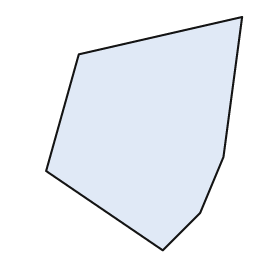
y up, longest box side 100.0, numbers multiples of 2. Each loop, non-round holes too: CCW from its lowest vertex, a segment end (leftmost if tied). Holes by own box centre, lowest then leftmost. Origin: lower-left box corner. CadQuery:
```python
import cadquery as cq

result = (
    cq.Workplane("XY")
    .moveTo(50.0, 0.0)
    .lineTo(66.0, 16.0)
    .lineTo(76.0, 40.0)
    .lineTo(84.0, 100.0)
    .lineTo(14.0, 84.0)
    .lineTo(0.0, 34.0)
    .close()
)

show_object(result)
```